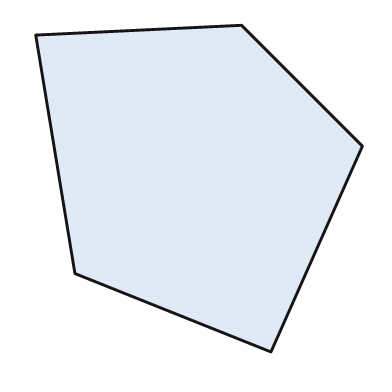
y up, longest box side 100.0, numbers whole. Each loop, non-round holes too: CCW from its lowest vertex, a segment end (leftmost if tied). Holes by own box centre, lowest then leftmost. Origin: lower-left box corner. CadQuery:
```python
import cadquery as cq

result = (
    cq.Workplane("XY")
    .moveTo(72.0, 0.0)
    .lineTo(100.0, 63.0)
    .lineTo(63.0, 100.0)
    .lineTo(0.0, 97.0)
    .lineTo(12.0, 24.0)
    .close()
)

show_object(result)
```